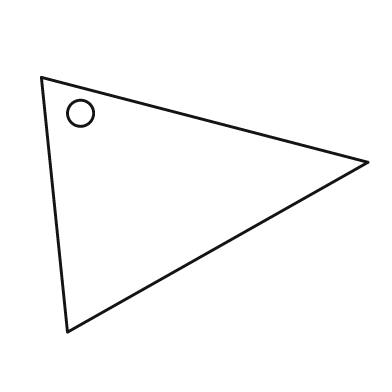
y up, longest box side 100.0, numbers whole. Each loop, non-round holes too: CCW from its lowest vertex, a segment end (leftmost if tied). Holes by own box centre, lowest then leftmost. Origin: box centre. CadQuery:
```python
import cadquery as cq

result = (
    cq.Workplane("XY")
    .moveTo(-42.0, -39.0)
    .lineTo(50.0, 13.0)
    .lineTo(-50.0, 39.0)
    .close()
    .moveTo(-38.0, 28.0)
    .circle(4.0)
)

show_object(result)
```